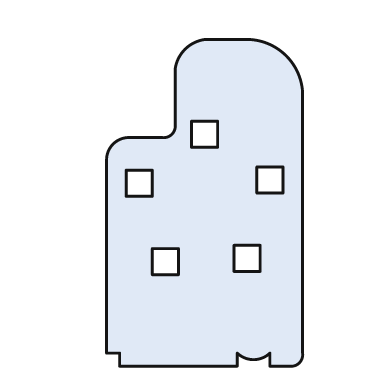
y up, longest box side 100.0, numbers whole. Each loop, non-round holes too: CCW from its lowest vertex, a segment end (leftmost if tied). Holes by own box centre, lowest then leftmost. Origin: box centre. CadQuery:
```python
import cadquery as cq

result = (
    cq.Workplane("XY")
    .moveTo(-26.0, -50.0)
    .lineTo(10.0, -50.0)
    .lineTo(10.0, -46.0)
    .threePointArc((15.0, -48.0), (20.0, -46.0))
    .lineTo(20.0, -50.0)
    .lineTo(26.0, -50.0)
    .threePointArc((29.0, -49.0), (30.0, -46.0))
    .lineTo(30.0, 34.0)
    .threePointArc((25.0, 45.0), (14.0, 50.0))
    .lineTo(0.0, 50.0)
    .threePointArc((-6.0, 47.0), (-9.0, 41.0))
    .lineTo(-9.0, 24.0)
    .threePointArc((-10.0, 21.0), (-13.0, 20.0))
    .lineTo(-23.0, 20.0)
    .threePointArc((-28.0, 18.0), (-30.0, 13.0))
    .lineTo(-30.0, -46.0)
    .lineTo(-26.0, -46.0)
    .close()
    .moveTo(-16.0, -22.0)
    .lineTo(-8.0, -22.0)
    .lineTo(-8.0, -14.0)
    .lineTo(-16.0, -14.0)
    .close()
    .moveTo(9.0, -21.0)
    .lineTo(17.0, -21.0)
    .lineTo(17.0, -13.0)
    .lineTo(9.0, -13.0)
    .close()
    .moveTo(-24.0, 2.0)
    .lineTo(-16.0, 2.0)
    .lineTo(-16.0, 10.0)
    .lineTo(-24.0, 10.0)
    .close()
    .moveTo(16.0, 3.0)
    .lineTo(24.0, 3.0)
    .lineTo(24.0, 11.0)
    .lineTo(16.0, 11.0)
    .close()
    .moveTo(-4.0, 17.0)
    .lineTo(4.0, 17.0)
    .lineTo(4.0, 25.0)
    .lineTo(-4.0, 25.0)
    .close()
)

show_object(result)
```